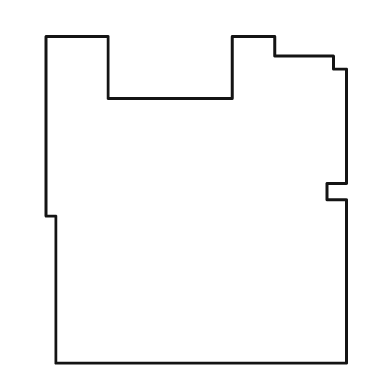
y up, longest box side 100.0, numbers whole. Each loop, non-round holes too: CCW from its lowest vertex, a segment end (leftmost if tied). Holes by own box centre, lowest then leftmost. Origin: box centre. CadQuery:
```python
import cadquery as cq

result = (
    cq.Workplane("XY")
    .moveTo(-43.0, -50.0)
    .lineTo(46.0, -50.0)
    .lineTo(46.0, 0.0)
    .lineTo(40.0, 0.0)
    .lineTo(40.0, 5.0)
    .lineTo(46.0, 5.0)
    .lineTo(46.0, 40.0)
    .lineTo(42.0, 40.0)
    .lineTo(42.0, 44.0)
    .lineTo(24.0, 44.0)
    .lineTo(24.0, 50.0)
    .lineTo(11.0, 50.0)
    .lineTo(11.0, 31.0)
    .lineTo(-27.0, 31.0)
    .lineTo(-27.0, 50.0)
    .lineTo(-46.0, 50.0)
    .lineTo(-46.0, -5.0)
    .lineTo(-43.0, -5.0)
    .close()
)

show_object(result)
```